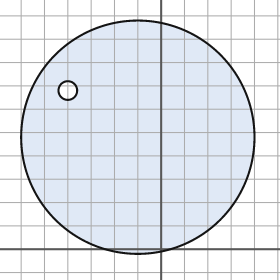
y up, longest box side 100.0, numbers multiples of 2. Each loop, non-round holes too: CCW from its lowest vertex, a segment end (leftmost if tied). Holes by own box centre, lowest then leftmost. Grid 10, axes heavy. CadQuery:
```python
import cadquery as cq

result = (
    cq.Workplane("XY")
    .moveTo(-10.0, 48.0)
    .circle(50.0)
    .moveTo(-40.0, 68.0)
    .circle(4.0)
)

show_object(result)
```